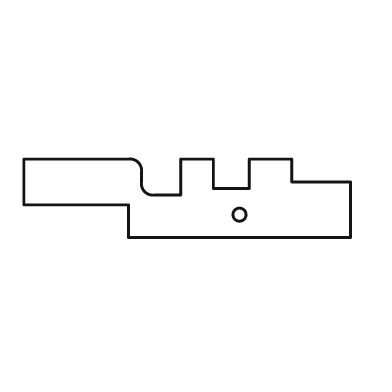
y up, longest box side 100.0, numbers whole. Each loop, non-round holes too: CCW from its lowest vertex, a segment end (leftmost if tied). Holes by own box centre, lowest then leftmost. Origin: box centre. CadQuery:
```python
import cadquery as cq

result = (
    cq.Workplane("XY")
    .moveTo(-18.0, -12.0)
    .lineTo(50.0, -12.0)
    .lineTo(50.0, 5.0)
    .lineTo(32.0, 5.0)
    .lineTo(32.0, 12.0)
    .lineTo(19.0, 12.0)
    .lineTo(19.0, 3.0)
    .lineTo(8.0, 3.0)
    .lineTo(8.0, 12.0)
    .lineTo(-2.0, 12.0)
    .lineTo(-2.0, 1.0)
    .lineTo(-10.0, 1.0)
    .threePointArc((-13.0, 2.0), (-14.0, 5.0))
    .lineTo(-14.0, 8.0)
    .threePointArc((-15.0, 11.0), (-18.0, 12.0))
    .lineTo(-50.0, 12.0)
    .lineTo(-50.0, -2.0)
    .lineTo(-18.0, -2.0)
    .close()
    .moveTo(16.0, -5.0)
    .circle(2.0)
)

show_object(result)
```